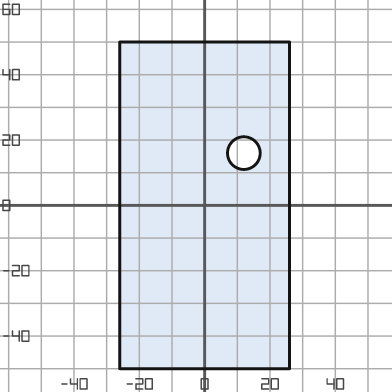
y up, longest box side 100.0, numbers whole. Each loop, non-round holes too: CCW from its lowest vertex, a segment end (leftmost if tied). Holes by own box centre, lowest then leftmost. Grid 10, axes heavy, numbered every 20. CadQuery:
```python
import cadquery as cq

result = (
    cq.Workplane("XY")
    .moveTo(-26.0, -50.0)
    .lineTo(26.0, -50.0)
    .lineTo(26.0, 50.0)
    .lineTo(-26.0, 50.0)
    .close()
    .moveTo(12.0, 16.0)
    .circle(5.0)
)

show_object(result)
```